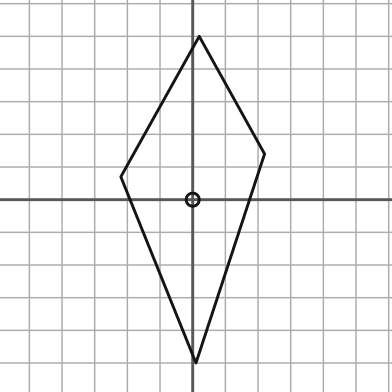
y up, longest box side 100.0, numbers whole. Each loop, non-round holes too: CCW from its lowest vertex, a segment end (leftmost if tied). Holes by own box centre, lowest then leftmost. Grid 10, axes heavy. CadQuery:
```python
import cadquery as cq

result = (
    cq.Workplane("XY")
    .moveTo(1.0, -50.0)
    .lineTo(22.0, 14.0)
    .lineTo(2.0, 50.0)
    .lineTo(-22.0, 7.0)
    .close()
    .moveTo(0.0, 0.0)
    .circle(2.0)
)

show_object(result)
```